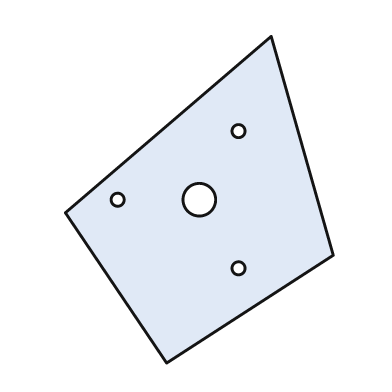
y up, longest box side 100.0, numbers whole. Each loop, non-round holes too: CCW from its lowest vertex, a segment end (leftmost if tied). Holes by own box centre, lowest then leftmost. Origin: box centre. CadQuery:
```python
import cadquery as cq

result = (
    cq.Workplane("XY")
    .moveTo(-10.0, -50.0)
    .lineTo(41.0, -17.0)
    .lineTo(22.0, 50.0)
    .lineTo(-41.0, -4.0)
    .close()
    .moveTo(12.0, -21.0)
    .circle(2.0)
    .moveTo(-25.0, 0.0)
    .circle(2.0)
    .moveTo(0.0, 0.0)
    .circle(5.0)
    .moveTo(12.0, 21.0)
    .circle(2.0)
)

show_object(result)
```